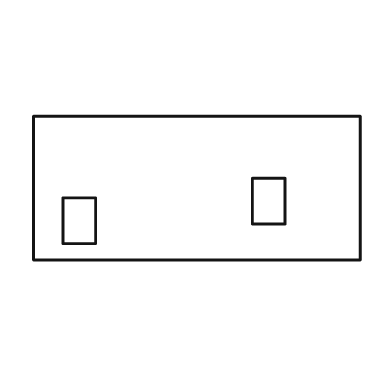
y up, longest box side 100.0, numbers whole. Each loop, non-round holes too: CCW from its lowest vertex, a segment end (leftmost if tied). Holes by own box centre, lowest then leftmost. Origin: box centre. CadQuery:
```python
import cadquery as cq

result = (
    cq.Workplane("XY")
    .moveTo(-50.0, -22.0)
    .lineTo(50.0, -22.0)
    .lineTo(50.0, 22.0)
    .lineTo(-50.0, 22.0)
    .close()
    .moveTo(-41.0, -17.0)
    .lineTo(-31.0, -17.0)
    .lineTo(-31.0, -3.0)
    .lineTo(-41.0, -3.0)
    .close()
    .moveTo(17.0, -11.0)
    .lineTo(27.0, -11.0)
    .lineTo(27.0, 3.0)
    .lineTo(17.0, 3.0)
    .close()
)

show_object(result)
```